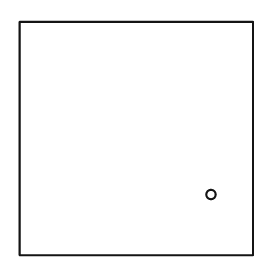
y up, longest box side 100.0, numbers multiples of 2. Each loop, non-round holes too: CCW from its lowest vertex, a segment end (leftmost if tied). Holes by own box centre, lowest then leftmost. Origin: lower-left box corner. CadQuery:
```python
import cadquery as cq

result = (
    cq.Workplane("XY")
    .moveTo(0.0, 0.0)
    .lineTo(100.0, 0.0)
    .lineTo(100.0, 100.0)
    .lineTo(0.0, 100.0)
    .close()
    .moveTo(82.0, 26.0)
    .circle(2.0)
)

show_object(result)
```